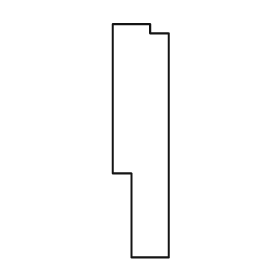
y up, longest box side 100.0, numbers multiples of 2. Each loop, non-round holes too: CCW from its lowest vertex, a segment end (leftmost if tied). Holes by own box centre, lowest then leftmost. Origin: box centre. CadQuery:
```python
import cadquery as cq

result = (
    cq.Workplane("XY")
    .moveTo(-4.0, -50.0)
    .lineTo(12.0, -50.0)
    .lineTo(12.0, 46.0)
    .lineTo(4.0, 46.0)
    .lineTo(4.0, 50.0)
    .lineTo(-12.0, 50.0)
    .lineTo(-12.0, -14.0)
    .lineTo(-4.0, -14.0)
    .close()
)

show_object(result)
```